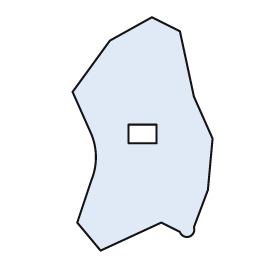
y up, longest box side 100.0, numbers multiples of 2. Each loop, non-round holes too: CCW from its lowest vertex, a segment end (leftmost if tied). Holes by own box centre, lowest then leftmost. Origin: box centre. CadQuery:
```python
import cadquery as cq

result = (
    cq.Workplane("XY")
    .moveTo(-18.0, -50.0)
    .lineTo(8.0, -38.0)
    .lineTo(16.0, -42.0)
    .threePointArc((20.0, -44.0), (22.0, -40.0))
    .lineTo(28.0, -24.0)
    .lineTo(30.0, -2.0)
    .lineTo(22.0, 16.0)
    .lineTo(16.0, 44.0)
    .lineTo(4.0, 50.0)
    .lineTo(-14.0, 40.0)
    .lineTo(-30.0, 18.0)
    .lineTo(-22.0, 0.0)
    .threePointArc((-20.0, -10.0), (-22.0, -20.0))
    .lineTo(-28.0, -38.0)
    .close()
    .moveTo(-6.0, -4.0)
    .lineTo(6.0, -4.0)
    .lineTo(6.0, 4.0)
    .lineTo(-6.0, 4.0)
    .close()
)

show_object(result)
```